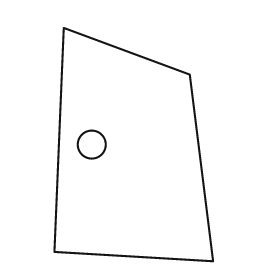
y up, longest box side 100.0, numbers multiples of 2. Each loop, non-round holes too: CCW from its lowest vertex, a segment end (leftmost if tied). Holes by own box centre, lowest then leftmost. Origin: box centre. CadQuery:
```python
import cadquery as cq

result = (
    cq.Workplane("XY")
    .moveTo(34.0, -50.0)
    .lineTo(24.0, 30.0)
    .lineTo(-30.0, 50.0)
    .lineTo(-34.0, -46.0)
    .close()
    .moveTo(-18.0, 0.0)
    .circle(6.0)
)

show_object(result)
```